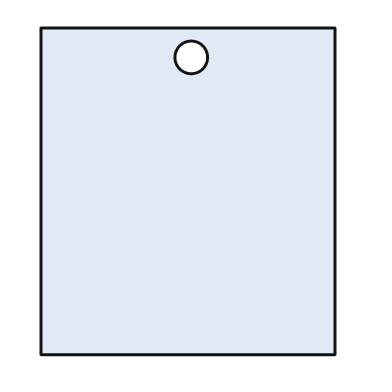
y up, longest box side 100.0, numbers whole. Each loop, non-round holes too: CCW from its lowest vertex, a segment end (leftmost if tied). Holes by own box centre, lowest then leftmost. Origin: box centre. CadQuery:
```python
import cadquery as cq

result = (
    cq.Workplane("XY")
    .moveTo(-45.0, -50.0)
    .lineTo(45.0, -50.0)
    .lineTo(45.0, 50.0)
    .lineTo(-45.0, 50.0)
    .close()
    .moveTo(1.0, 41.0)
    .circle(5.0)
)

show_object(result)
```